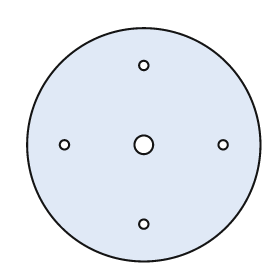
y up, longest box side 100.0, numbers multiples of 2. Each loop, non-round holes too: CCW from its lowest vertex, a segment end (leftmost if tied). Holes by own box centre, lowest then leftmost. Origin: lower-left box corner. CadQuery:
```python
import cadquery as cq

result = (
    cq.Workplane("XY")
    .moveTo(50.0, 50.0)
    .circle(50.0)
    .moveTo(50.0, 16.0)
    .circle(2.0)
    .moveTo(16.0, 50.0)
    .circle(2.0)
    .moveTo(50.0, 50.0)
    .circle(4.0)
    .moveTo(84.0, 50.0)
    .circle(2.0)
    .moveTo(50.0, 84.0)
    .circle(2.0)
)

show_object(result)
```